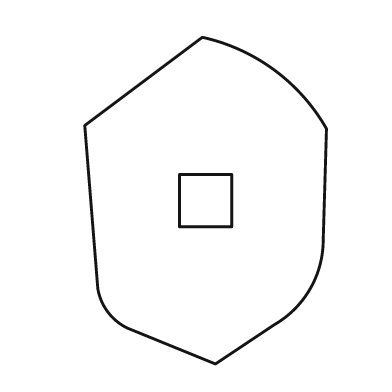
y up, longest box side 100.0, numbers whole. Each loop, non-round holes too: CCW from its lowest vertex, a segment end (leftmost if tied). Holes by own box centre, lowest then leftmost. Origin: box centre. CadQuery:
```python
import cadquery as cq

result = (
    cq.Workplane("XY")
    .moveTo(3.0, -50.0)
    .lineTo(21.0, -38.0)
    .threePointArc((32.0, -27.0), (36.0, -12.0))
    .lineTo(37.0, 22.0)
    .threePointArc((21.0, 40.0), (-1.0, 50.0))
    .lineTo(-37.0, 23.0)
    .lineTo(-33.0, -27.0)
    .threePointArc((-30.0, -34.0), (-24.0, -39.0))
    .close()
    .moveTo(-8.0, -8.0)
    .lineTo(8.0, -8.0)
    .lineTo(8.0, 8.0)
    .lineTo(-8.0, 8.0)
    .close()
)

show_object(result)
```